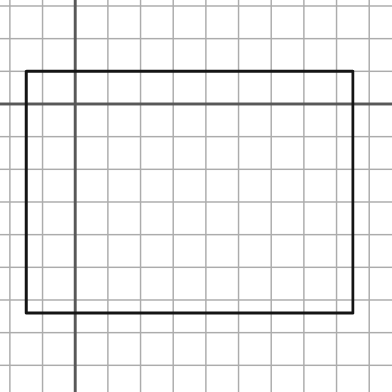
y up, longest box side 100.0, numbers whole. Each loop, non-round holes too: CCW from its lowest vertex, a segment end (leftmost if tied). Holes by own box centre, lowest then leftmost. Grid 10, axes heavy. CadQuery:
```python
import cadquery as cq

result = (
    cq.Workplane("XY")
    .moveTo(-15.0, -64.0)
    .lineTo(85.0, -64.0)
    .lineTo(85.0, 10.0)
    .lineTo(-15.0, 10.0)
    .close()
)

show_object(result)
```